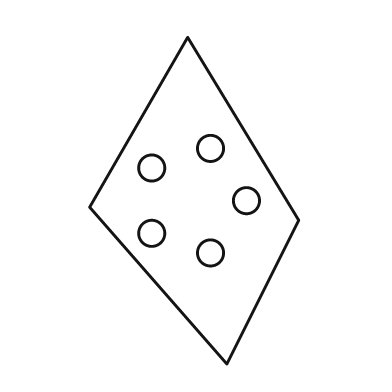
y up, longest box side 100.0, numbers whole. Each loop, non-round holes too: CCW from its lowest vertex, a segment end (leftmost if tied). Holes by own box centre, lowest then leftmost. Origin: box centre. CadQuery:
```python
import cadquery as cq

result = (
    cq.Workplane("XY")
    .moveTo(10.0, -50.0)
    .lineTo(32.0, -6.0)
    .lineTo(-2.0, 50.0)
    .lineTo(-32.0, -2.0)
    .close()
    .moveTo(5.0, -16.0)
    .circle(4.0)
    .moveTo(-13.0, -10.0)
    .circle(4.0)
    .moveTo(16.0, 0.0)
    .circle(4.0)
    .moveTo(-13.0, 10.0)
    .circle(4.0)
    .moveTo(5.0, 16.0)
    .circle(4.0)
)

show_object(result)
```